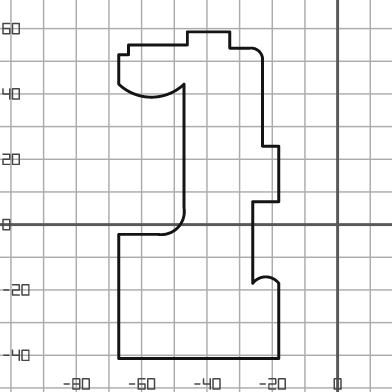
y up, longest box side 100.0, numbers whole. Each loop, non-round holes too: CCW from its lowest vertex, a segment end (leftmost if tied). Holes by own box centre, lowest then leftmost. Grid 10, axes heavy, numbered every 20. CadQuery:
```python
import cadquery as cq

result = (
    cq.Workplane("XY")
    .moveTo(-67.0, -41.0)
    .lineTo(-18.0, -41.0)
    .lineTo(-18.0, -18.0)
    .threePointArc((-22.0, -16.0), (-26.0, -18.0))
    .lineTo(-26.0, 7.0)
    .lineTo(-18.0, 7.0)
    .lineTo(-18.0, 24.0)
    .lineTo(-23.0, 24.0)
    .lineTo(-23.0, 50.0)
    .threePointArc((-24.0, 53.0), (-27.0, 54.0))
    .lineTo(-33.0, 54.0)
    .lineTo(-33.0, 59.0)
    .lineTo(-46.0, 59.0)
    .lineTo(-46.0, 55.0)
    .lineTo(-64.0, 55.0)
    .lineTo(-64.0, 52.0)
    .lineTo(-67.0, 52.0)
    .lineTo(-67.0, 43.0)
    .threePointArc((-57.0, 39.0), (-47.0, 43.0))
    .lineTo(-47.0, 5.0)
    .threePointArc((-49.0, -1.0), (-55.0, -3.0))
    .lineTo(-67.0, -3.0)
    .close()
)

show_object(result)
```